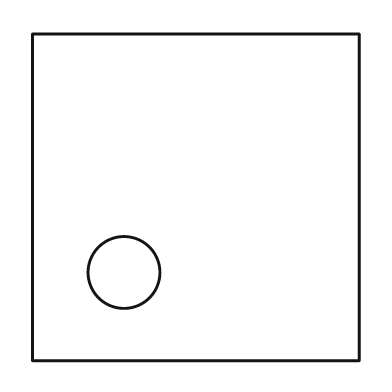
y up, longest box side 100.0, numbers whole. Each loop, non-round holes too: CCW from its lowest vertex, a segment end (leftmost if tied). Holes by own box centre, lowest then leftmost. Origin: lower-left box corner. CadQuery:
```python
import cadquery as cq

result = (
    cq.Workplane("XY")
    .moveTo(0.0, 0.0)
    .lineTo(100.0, 0.0)
    .lineTo(100.0, 100.0)
    .lineTo(0.0, 100.0)
    .close()
    .moveTo(28.0, 27.0)
    .circle(11.0)
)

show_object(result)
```